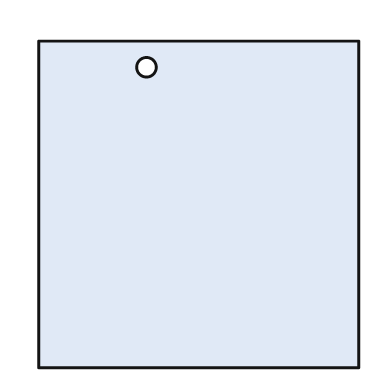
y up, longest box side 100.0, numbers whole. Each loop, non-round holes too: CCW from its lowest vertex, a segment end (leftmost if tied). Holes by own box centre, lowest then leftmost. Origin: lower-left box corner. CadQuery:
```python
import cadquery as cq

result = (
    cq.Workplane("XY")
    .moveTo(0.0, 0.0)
    .lineTo(98.0, 0.0)
    .lineTo(98.0, 100.0)
    .lineTo(0.0, 100.0)
    .close()
    .moveTo(33.0, 92.0)
    .circle(3.0)
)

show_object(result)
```